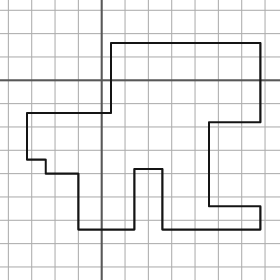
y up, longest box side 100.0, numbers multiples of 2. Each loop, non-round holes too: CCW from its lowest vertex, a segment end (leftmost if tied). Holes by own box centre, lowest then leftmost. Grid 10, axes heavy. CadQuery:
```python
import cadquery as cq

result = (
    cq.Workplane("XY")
    .moveTo(-10.0, -64.0)
    .lineTo(14.0, -64.0)
    .lineTo(14.0, -38.0)
    .lineTo(26.0, -38.0)
    .lineTo(26.0, -64.0)
    .lineTo(68.0, -64.0)
    .lineTo(68.0, -54.0)
    .lineTo(46.0, -54.0)
    .lineTo(46.0, -18.0)
    .lineTo(68.0, -18.0)
    .lineTo(68.0, 16.0)
    .lineTo(4.0, 16.0)
    .lineTo(4.0, -14.0)
    .lineTo(-32.0, -14.0)
    .lineTo(-32.0, -34.0)
    .lineTo(-24.0, -34.0)
    .lineTo(-24.0, -40.0)
    .lineTo(-10.0, -40.0)
    .close()
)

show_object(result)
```